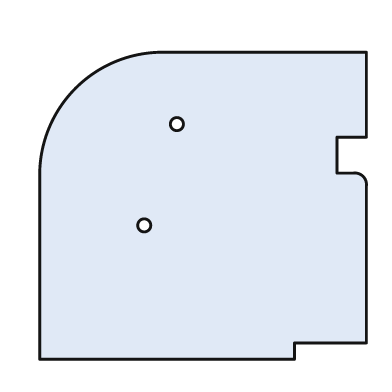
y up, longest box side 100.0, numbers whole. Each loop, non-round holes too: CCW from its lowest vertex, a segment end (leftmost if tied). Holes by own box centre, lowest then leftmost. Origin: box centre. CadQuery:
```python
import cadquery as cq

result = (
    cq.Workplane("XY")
    .moveTo(-50.0, -47.0)
    .lineTo(28.0, -47.0)
    .lineTo(28.0, -42.0)
    .lineTo(50.0, -42.0)
    .lineTo(50.0, 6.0)
    .threePointArc((49.0, 9.0), (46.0, 10.0))
    .lineTo(41.0, 10.0)
    .lineTo(41.0, 21.0)
    .lineTo(50.0, 21.0)
    .lineTo(50.0, 47.0)
    .lineTo(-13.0, 47.0)
    .threePointArc((-39.0, 36.0), (-50.0, 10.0))
    .close()
    .moveTo(-18.0, -6.0)
    .circle(2.0)
    .moveTo(-8.0, 25.0)
    .circle(2.0)
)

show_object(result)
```